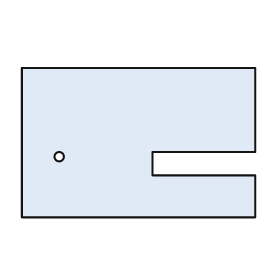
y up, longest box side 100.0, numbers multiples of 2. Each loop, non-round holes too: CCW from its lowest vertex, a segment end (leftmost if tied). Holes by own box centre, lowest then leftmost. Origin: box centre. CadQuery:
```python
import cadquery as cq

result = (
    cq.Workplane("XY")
    .moveTo(-50.0, -32.0)
    .lineTo(50.0, -32.0)
    .lineTo(50.0, -14.0)
    .lineTo(6.0, -14.0)
    .lineTo(6.0, -4.0)
    .lineTo(50.0, -4.0)
    .lineTo(50.0, 32.0)
    .lineTo(-50.0, 32.0)
    .close()
    .moveTo(-34.0, -6.0)
    .circle(2.0)
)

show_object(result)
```